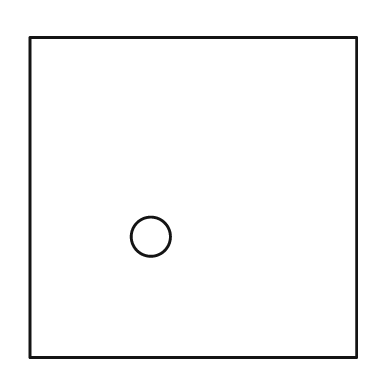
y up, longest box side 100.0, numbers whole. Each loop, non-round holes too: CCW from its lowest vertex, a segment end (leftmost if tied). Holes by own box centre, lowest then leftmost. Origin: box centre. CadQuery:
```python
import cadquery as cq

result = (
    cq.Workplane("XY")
    .moveTo(-50.0, -49.0)
    .lineTo(50.0, -49.0)
    .lineTo(50.0, 49.0)
    .lineTo(-50.0, 49.0)
    .close()
    .moveTo(-13.0, -12.0)
    .circle(6.0)
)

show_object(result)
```